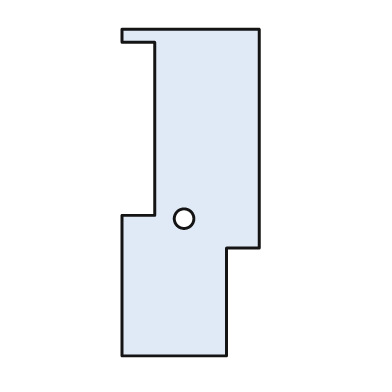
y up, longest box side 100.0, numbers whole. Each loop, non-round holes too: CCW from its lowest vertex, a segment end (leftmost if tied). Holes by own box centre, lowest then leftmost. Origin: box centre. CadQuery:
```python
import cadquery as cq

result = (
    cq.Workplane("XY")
    .moveTo(-21.0, -50.0)
    .lineTo(11.0, -50.0)
    .lineTo(11.0, -17.0)
    .lineTo(21.0, -17.0)
    .lineTo(21.0, 50.0)
    .lineTo(-21.0, 50.0)
    .lineTo(-21.0, 46.0)
    .lineTo(-11.0, 46.0)
    .lineTo(-11.0, -7.0)
    .lineTo(-21.0, -7.0)
    .close()
    .moveTo(-2.0, -8.0)
    .circle(3.0)
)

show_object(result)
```